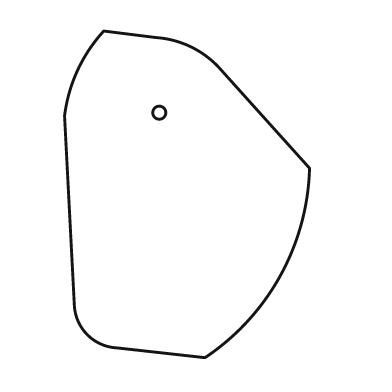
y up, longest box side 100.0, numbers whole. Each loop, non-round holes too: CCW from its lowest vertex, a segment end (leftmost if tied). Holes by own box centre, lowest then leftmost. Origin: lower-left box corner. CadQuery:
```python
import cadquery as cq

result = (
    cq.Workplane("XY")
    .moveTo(43.0, 0.0)
    .threePointArc((66.0, 25.0), (75.0, 58.0))
    .lineTo(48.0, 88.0)
    .threePointArc((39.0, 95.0), (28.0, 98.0))
    .lineTo(12.0, 100.0)
    .threePointArc((4.0, 88.0), (0.0, 74.0))
    .lineTo(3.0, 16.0)
    .threePointArc((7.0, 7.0), (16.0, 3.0))
    .close()
    .moveTo(29.0, 75.0)
    .circle(2.0)
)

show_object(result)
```